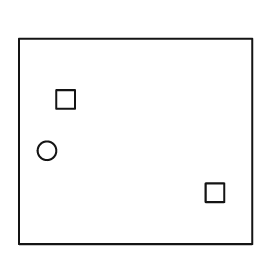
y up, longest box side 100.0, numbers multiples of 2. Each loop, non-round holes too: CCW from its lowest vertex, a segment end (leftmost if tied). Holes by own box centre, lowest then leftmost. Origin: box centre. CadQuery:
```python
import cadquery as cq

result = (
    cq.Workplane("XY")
    .moveTo(-50.0, -44.0)
    .lineTo(50.0, -44.0)
    .lineTo(50.0, 44.0)
    .lineTo(-50.0, 44.0)
    .close()
    .moveTo(30.0, -26.0)
    .lineTo(38.0, -26.0)
    .lineTo(38.0, -18.0)
    .lineTo(30.0, -18.0)
    .close()
    .moveTo(-38.0, -4.0)
    .circle(4.0)
    .moveTo(-34.0, 14.0)
    .lineTo(-26.0, 14.0)
    .lineTo(-26.0, 22.0)
    .lineTo(-34.0, 22.0)
    .close()
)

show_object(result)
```